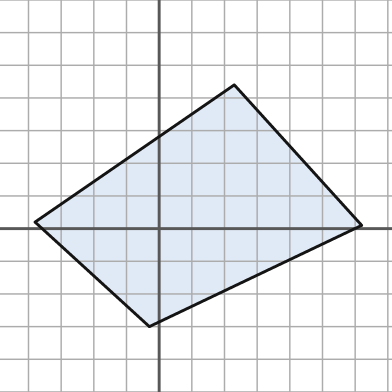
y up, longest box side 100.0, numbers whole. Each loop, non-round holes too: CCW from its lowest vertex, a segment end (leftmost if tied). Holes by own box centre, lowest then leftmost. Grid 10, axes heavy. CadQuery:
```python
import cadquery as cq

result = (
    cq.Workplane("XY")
    .moveTo(-3.0, -30.0)
    .lineTo(62.0, 1.0)
    .lineTo(23.0, 44.0)
    .lineTo(-38.0, 2.0)
    .close()
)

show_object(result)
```